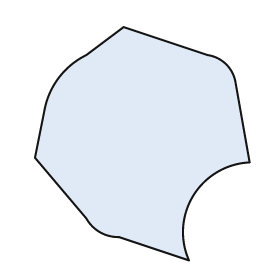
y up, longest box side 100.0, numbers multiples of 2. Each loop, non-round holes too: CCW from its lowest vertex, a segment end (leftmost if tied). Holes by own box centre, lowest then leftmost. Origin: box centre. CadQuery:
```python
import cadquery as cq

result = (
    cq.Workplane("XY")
    .moveTo(20.0, -50.0)
    .threePointArc((22.0, -22.0), (46.0, -8.0))
    .lineTo(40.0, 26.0)
    .threePointArc((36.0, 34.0), (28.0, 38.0))
    .lineTo(-8.0, 50.0)
    .lineTo(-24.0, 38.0)
    .threePointArc((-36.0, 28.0), (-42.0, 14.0))
    .lineTo(-46.0, -6.0)
    .lineTo(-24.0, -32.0)
    .threePointArc((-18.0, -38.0), (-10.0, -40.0))
    .close()
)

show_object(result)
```